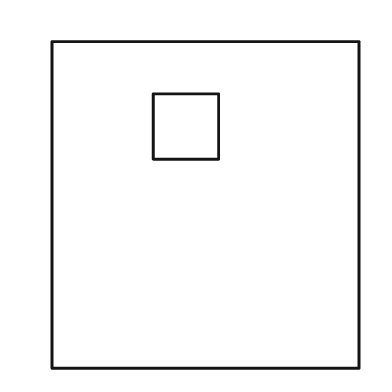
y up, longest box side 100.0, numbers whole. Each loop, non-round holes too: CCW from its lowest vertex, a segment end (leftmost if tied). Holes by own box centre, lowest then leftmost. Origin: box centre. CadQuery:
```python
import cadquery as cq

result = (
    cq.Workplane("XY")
    .moveTo(-47.0, -50.0)
    .lineTo(47.0, -50.0)
    .lineTo(47.0, 50.0)
    .lineTo(-47.0, 50.0)
    .close()
    .moveTo(-16.0, 14.0)
    .lineTo(4.0, 14.0)
    .lineTo(4.0, 34.0)
    .lineTo(-16.0, 34.0)
    .close()
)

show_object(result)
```